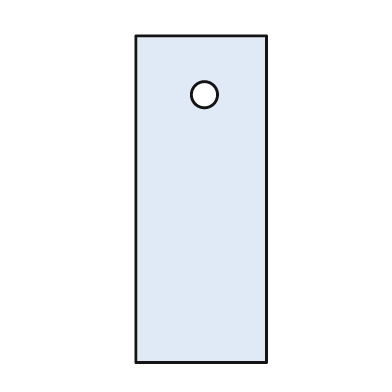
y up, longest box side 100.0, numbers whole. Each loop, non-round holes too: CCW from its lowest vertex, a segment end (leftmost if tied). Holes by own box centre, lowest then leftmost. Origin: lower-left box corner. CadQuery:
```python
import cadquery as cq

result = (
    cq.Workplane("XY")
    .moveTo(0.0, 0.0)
    .lineTo(40.0, 0.0)
    .lineTo(40.0, 100.0)
    .lineTo(0.0, 100.0)
    .close()
    .moveTo(21.0, 82.0)
    .circle(4.0)
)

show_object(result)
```